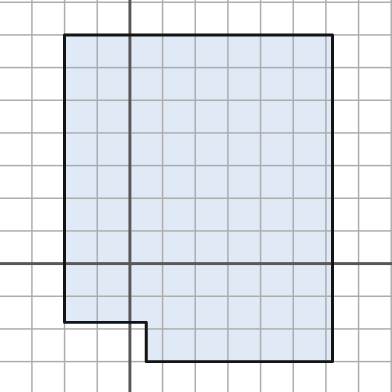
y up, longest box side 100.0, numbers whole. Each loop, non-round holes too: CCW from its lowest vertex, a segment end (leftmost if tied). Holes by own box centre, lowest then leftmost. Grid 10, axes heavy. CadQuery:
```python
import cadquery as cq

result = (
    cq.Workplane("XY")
    .moveTo(5.0, -30.0)
    .lineTo(62.0, -30.0)
    .lineTo(62.0, 70.0)
    .lineTo(-20.0, 70.0)
    .lineTo(-20.0, -18.0)
    .lineTo(5.0, -18.0)
    .close()
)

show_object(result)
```